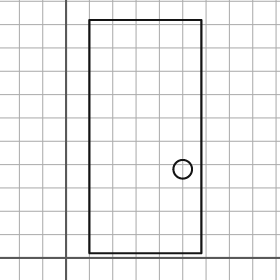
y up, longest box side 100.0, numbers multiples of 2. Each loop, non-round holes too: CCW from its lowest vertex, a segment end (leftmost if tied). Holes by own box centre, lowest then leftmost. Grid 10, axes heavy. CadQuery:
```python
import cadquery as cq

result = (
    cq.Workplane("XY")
    .moveTo(10.0, 2.0)
    .lineTo(58.0, 2.0)
    .lineTo(58.0, 102.0)
    .lineTo(10.0, 102.0)
    .close()
    .moveTo(50.0, 38.0)
    .circle(4.0)
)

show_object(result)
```